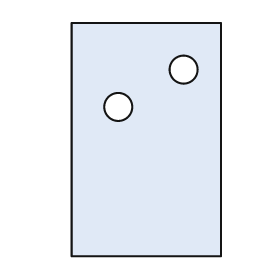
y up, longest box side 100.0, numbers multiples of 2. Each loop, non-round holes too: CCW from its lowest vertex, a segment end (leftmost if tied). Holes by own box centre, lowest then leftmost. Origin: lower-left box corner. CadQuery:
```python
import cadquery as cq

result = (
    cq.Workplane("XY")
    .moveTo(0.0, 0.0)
    .lineTo(64.0, 0.0)
    .lineTo(64.0, 100.0)
    .lineTo(0.0, 100.0)
    .close()
    .moveTo(20.0, 64.0)
    .circle(6.0)
    .moveTo(48.0, 80.0)
    .circle(6.0)
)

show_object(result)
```